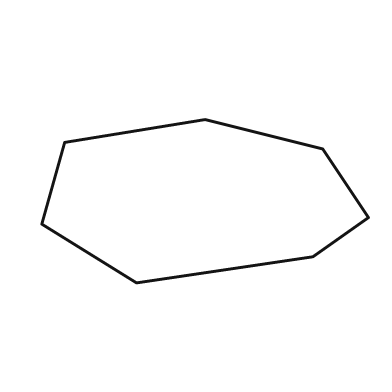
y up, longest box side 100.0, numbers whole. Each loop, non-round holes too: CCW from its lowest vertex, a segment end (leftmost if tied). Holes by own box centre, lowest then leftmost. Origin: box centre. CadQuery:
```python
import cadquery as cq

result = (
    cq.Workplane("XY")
    .moveTo(-21.0, -25.0)
    .lineTo(33.0, -17.0)
    .lineTo(50.0, -5.0)
    .lineTo(36.0, 16.0)
    .lineTo(0.0, 25.0)
    .lineTo(-43.0, 18.0)
    .lineTo(-50.0, -7.0)
    .close()
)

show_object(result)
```